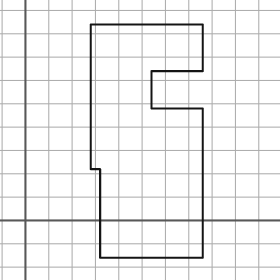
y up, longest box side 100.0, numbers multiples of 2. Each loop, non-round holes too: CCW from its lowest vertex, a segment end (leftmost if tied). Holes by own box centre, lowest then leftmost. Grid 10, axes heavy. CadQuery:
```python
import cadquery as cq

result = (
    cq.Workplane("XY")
    .moveTo(32.0, -16.0)
    .lineTo(76.0, -16.0)
    .lineTo(76.0, 48.0)
    .lineTo(54.0, 48.0)
    .lineTo(54.0, 64.0)
    .lineTo(76.0, 64.0)
    .lineTo(76.0, 84.0)
    .lineTo(28.0, 84.0)
    .lineTo(28.0, 22.0)
    .lineTo(32.0, 22.0)
    .close()
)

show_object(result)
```